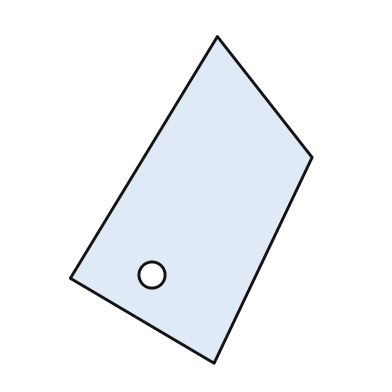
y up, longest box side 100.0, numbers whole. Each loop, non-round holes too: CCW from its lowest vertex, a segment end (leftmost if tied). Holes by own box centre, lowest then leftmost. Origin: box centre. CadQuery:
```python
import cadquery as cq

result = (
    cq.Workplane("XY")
    .moveTo(7.0, -50.0)
    .lineTo(37.0, 13.0)
    .lineTo(8.0, 50.0)
    .lineTo(-37.0, -24.0)
    .close()
    .moveTo(-12.0, -23.0)
    .circle(4.0)
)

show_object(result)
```